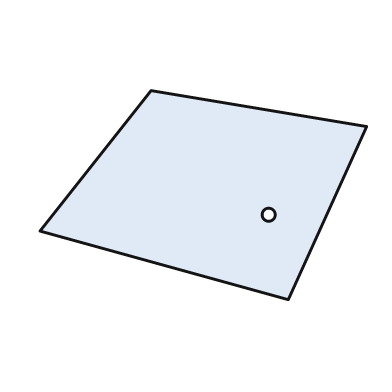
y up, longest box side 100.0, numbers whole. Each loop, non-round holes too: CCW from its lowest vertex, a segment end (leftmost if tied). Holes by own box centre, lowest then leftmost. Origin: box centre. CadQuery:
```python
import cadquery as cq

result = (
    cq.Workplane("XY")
    .moveTo(26.0, -32.0)
    .lineTo(50.0, 21.0)
    .lineTo(-16.0, 32.0)
    .lineTo(-50.0, -11.0)
    .close()
    .moveTo(20.0, -6.0)
    .circle(2.0)
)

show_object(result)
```